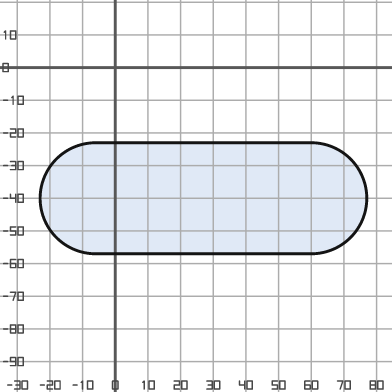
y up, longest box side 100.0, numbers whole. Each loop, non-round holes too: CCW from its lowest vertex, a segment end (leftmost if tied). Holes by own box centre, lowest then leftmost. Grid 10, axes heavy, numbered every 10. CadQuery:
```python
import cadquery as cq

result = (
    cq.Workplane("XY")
    .moveTo(-6.0, -57.0)
    .lineTo(60.0, -57.0)
    .threePointArc((77.0, -40.0), (60.0, -23.0))
    .lineTo(-6.0, -23.0)
    .threePointArc((-23.0, -40.0), (-6.0, -57.0))
    .close()
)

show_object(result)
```